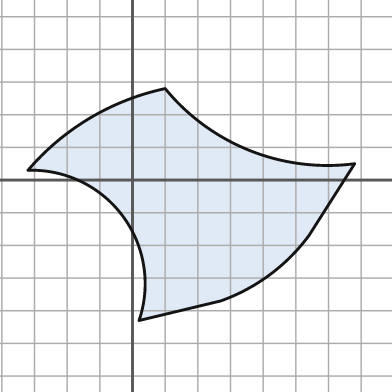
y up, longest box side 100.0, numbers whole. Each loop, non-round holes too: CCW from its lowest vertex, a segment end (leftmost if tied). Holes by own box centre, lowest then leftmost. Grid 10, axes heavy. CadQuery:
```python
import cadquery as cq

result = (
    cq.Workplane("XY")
    .moveTo(2.0, -43.0)
    .lineTo(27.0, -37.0)
    .threePointArc((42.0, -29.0), (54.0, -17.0))
    .lineTo(68.0, 5.0)
    .threePointArc((36.0, 9.0), (10.0, 28.0))
    .threePointArc((-13.0, 19.0), (-32.0, 3.0))
    .threePointArc((-3.0, -11.0), (2.0, -43.0))
    .close()
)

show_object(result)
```